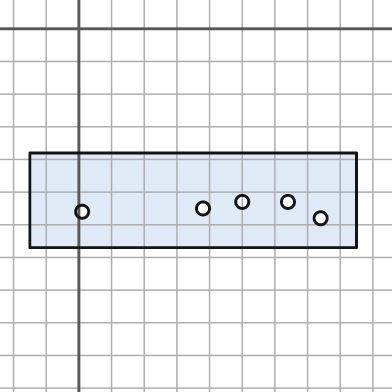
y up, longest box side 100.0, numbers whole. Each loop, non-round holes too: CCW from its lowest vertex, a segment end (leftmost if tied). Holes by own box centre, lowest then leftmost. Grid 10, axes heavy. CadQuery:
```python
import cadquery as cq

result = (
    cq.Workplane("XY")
    .moveTo(-15.0, -67.0)
    .lineTo(85.0, -67.0)
    .lineTo(85.0, -38.0)
    .lineTo(-15.0, -38.0)
    .close()
    .moveTo(74.0, -58.0)
    .circle(2.0)
    .moveTo(1.0, -56.0)
    .circle(2.0)
    .moveTo(38.0, -55.0)
    .circle(2.0)
    .moveTo(50.0, -53.0)
    .circle(2.0)
    .moveTo(64.0, -53.0)
    .circle(2.0)
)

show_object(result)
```